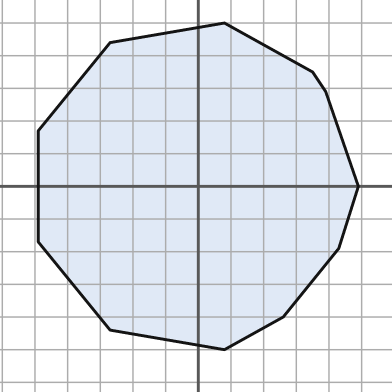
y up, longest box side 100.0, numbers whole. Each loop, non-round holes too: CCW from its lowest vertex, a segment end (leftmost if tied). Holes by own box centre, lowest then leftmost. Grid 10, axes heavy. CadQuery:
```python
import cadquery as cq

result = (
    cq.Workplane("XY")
    .moveTo(8.0, -50.0)
    .lineTo(26.0, -40.0)
    .lineTo(43.0, -19.0)
    .lineTo(49.0, 0.0)
    .lineTo(39.0, 29.0)
    .lineTo(35.0, 35.0)
    .lineTo(8.0, 50.0)
    .lineTo(-27.0, 44.0)
    .lineTo(-49.0, 17.0)
    .lineTo(-49.0, -17.0)
    .lineTo(-27.0, -44.0)
    .close()
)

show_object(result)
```